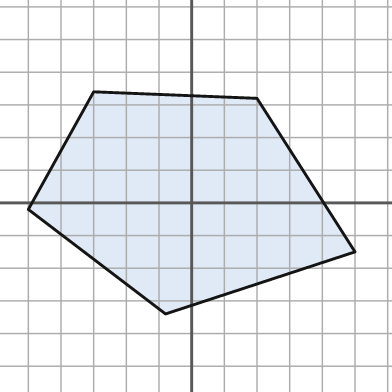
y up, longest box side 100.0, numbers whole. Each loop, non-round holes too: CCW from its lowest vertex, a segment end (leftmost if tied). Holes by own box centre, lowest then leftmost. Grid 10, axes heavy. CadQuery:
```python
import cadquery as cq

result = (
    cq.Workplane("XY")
    .moveTo(-8.0, -34.0)
    .lineTo(50.0, -15.0)
    .lineTo(20.0, 32.0)
    .lineTo(-30.0, 34.0)
    .lineTo(-50.0, -2.0)
    .close()
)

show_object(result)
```